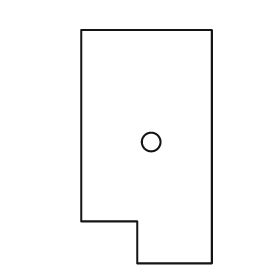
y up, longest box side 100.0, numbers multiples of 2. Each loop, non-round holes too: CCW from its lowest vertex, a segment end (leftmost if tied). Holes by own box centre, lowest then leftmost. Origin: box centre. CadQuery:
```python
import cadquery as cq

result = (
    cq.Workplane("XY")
    .moveTo(-4.0, -50.0)
    .lineTo(28.0, -50.0)
    .lineTo(28.0, 50.0)
    .lineTo(-28.0, 50.0)
    .lineTo(-28.0, -32.0)
    .lineTo(-4.0, -32.0)
    .close()
    .moveTo(2.0, 2.0)
    .circle(4.0)
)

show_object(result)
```